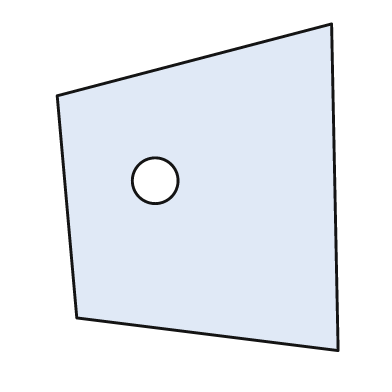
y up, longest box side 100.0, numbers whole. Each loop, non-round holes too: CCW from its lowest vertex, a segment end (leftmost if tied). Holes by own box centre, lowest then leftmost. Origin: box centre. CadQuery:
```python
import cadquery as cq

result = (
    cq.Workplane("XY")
    .moveTo(43.0, -50.0)
    .lineTo(41.0, 50.0)
    .lineTo(-43.0, 28.0)
    .lineTo(-37.0, -40.0)
    .close()
    .moveTo(-13.0, 2.0)
    .circle(7.0)
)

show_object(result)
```